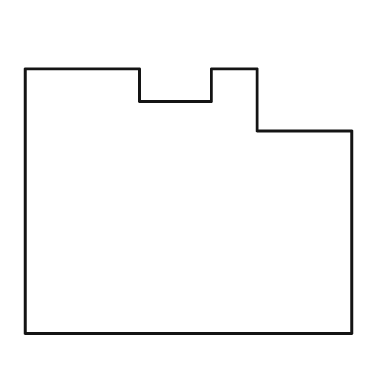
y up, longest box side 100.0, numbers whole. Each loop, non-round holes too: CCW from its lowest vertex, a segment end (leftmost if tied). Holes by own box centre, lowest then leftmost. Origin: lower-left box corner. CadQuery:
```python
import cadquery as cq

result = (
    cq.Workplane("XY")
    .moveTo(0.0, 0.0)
    .lineTo(100.0, 0.0)
    .lineTo(100.0, 62.0)
    .lineTo(71.0, 62.0)
    .lineTo(71.0, 81.0)
    .lineTo(57.0, 81.0)
    .lineTo(57.0, 71.0)
    .lineTo(35.0, 71.0)
    .lineTo(35.0, 81.0)
    .lineTo(0.0, 81.0)
    .close()
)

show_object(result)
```